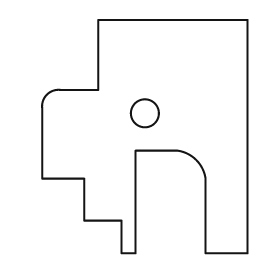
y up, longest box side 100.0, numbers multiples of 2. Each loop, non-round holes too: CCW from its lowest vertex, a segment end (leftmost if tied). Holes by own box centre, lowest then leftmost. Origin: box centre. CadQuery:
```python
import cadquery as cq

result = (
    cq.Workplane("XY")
    .moveTo(-10.0, -50.0)
    .lineTo(-4.0, -50.0)
    .lineTo(-4.0, -6.0)
    .lineTo(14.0, -6.0)
    .threePointArc((22.0, -10.0), (26.0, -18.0))
    .lineTo(26.0, -50.0)
    .lineTo(44.0, -50.0)
    .lineTo(44.0, 50.0)
    .lineTo(-20.0, 50.0)
    .lineTo(-20.0, 20.0)
    .lineTo(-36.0, 20.0)
    .threePointArc((-42.0, 18.0), (-44.0, 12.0))
    .lineTo(-44.0, -18.0)
    .lineTo(-26.0, -18.0)
    .lineTo(-26.0, -36.0)
    .lineTo(-10.0, -36.0)
    .close()
    .moveTo(0.0, 10.0)
    .circle(6.0)
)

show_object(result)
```